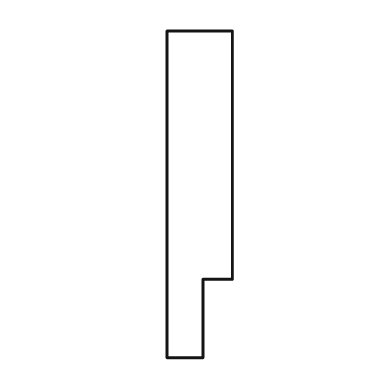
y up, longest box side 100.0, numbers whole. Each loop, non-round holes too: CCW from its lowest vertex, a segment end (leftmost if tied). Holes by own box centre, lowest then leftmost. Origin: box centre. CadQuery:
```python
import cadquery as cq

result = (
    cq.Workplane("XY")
    .moveTo(-10.0, -50.0)
    .lineTo(1.0, -50.0)
    .lineTo(1.0, -26.0)
    .lineTo(10.0, -26.0)
    .lineTo(10.0, 50.0)
    .lineTo(-10.0, 50.0)
    .close()
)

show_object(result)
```